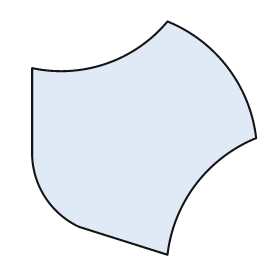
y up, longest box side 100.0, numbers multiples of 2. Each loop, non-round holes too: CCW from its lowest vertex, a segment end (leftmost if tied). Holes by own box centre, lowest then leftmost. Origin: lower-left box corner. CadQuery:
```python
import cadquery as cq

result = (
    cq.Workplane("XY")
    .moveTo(58.0, 0.0)
    .threePointArc((70.0, 30.0), (96.0, 50.0))
    .threePointArc((84.0, 80.0), (58.0, 100.0))
    .threePointArc((32.0, 82.0), (0.0, 80.0))
    .lineTo(0.0, 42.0)
    .threePointArc((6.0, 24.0), (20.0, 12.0))
    .close()
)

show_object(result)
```